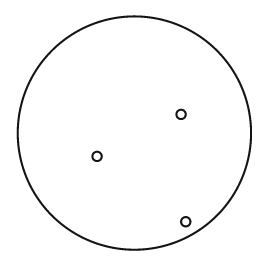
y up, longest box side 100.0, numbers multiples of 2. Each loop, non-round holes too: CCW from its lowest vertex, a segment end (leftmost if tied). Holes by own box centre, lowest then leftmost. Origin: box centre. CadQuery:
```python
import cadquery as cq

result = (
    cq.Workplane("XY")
    .moveTo(0.0, 0.0)
    .circle(50.0)
    .moveTo(22.0, -38.0)
    .circle(2.0)
    .moveTo(-16.0, -10.0)
    .circle(2.0)
    .moveTo(20.0, 8.0)
    .circle(2.0)
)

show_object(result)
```